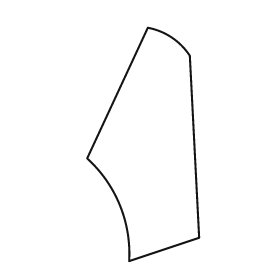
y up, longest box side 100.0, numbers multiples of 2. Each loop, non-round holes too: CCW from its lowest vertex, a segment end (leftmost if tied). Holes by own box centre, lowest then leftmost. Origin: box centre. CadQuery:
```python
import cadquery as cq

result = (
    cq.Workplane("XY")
    .moveTo(-6.0, -50.0)
    .lineTo(24.0, -40.0)
    .lineTo(20.0, 38.0)
    .threePointArc((12.0, 46.0), (2.0, 50.0))
    .lineTo(-24.0, -6.0)
    .threePointArc((-10.0, -26.0), (-6.0, -50.0))
    .close()
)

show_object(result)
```